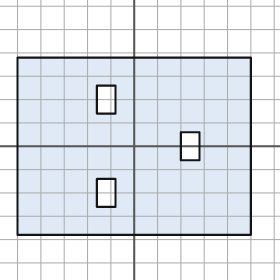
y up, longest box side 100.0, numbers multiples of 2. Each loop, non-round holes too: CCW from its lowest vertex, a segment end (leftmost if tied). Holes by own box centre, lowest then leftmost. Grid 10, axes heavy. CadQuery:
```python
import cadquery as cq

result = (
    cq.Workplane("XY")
    .moveTo(-50.0, -38.0)
    .lineTo(50.0, -38.0)
    .lineTo(50.0, 38.0)
    .lineTo(-50.0, 38.0)
    .close()
    .moveTo(-16.0, -26.0)
    .lineTo(-8.0, -26.0)
    .lineTo(-8.0, -14.0)
    .lineTo(-16.0, -14.0)
    .close()
    .moveTo(20.0, -6.0)
    .lineTo(28.0, -6.0)
    .lineTo(28.0, 6.0)
    .lineTo(20.0, 6.0)
    .close()
    .moveTo(-16.0, 14.0)
    .lineTo(-8.0, 14.0)
    .lineTo(-8.0, 26.0)
    .lineTo(-16.0, 26.0)
    .close()
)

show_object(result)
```